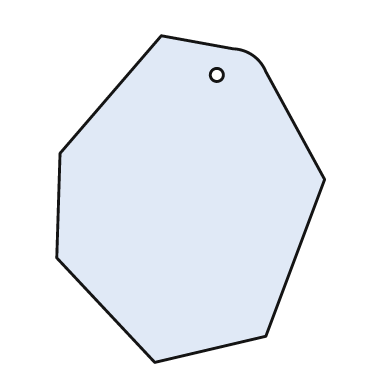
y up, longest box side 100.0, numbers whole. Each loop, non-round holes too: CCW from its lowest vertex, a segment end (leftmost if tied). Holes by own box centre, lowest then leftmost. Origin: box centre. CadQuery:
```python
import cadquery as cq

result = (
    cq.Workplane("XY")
    .moveTo(-11.0, -50.0)
    .lineTo(23.0, -42.0)
    .lineTo(41.0, 6.0)
    .lineTo(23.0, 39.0)
    .threePointArc((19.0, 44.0), (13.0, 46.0))
    .lineTo(-9.0, 50.0)
    .lineTo(-40.0, 14.0)
    .lineTo(-41.0, -18.0)
    .close()
    .moveTo(8.0, 38.0)
    .circle(2.0)
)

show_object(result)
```